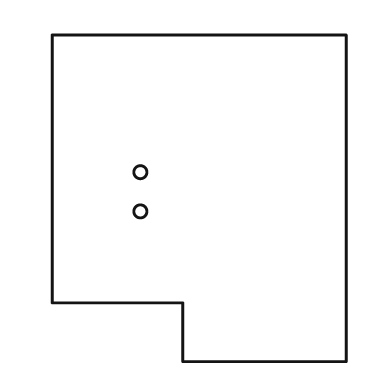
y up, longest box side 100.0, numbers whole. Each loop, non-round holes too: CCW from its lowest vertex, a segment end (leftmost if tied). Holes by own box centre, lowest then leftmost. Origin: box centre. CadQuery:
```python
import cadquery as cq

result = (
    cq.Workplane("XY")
    .moveTo(-5.0, -50.0)
    .lineTo(45.0, -50.0)
    .lineTo(45.0, 50.0)
    .lineTo(-45.0, 50.0)
    .lineTo(-45.0, -32.0)
    .lineTo(-5.0, -32.0)
    .close()
    .moveTo(-18.0, -4.0)
    .circle(2.0)
    .moveTo(-18.0, 8.0)
    .circle(2.0)
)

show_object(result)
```